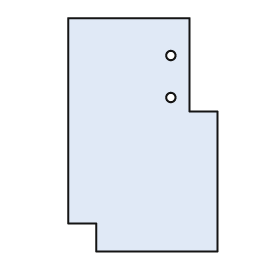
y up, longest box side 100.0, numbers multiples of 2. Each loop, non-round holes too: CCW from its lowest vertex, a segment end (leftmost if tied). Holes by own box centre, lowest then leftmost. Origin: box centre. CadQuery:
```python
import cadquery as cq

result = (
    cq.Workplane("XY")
    .moveTo(-20.0, -50.0)
    .lineTo(32.0, -50.0)
    .lineTo(32.0, 10.0)
    .lineTo(20.0, 10.0)
    .lineTo(20.0, 50.0)
    .lineTo(-32.0, 50.0)
    .lineTo(-32.0, -38.0)
    .lineTo(-20.0, -38.0)
    .close()
    .moveTo(12.0, 16.0)
    .circle(2.0)
    .moveTo(12.0, 34.0)
    .circle(2.0)
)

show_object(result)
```